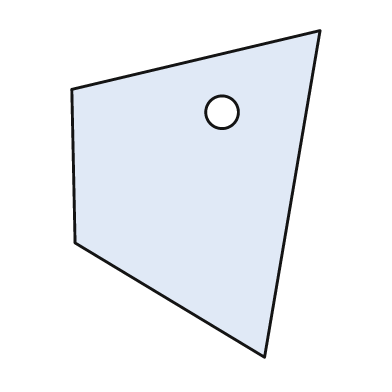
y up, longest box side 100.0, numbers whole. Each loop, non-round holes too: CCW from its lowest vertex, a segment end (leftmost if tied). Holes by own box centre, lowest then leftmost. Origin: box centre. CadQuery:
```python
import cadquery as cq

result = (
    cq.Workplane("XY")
    .moveTo(21.0, -50.0)
    .lineTo(38.0, 50.0)
    .lineTo(-38.0, 32.0)
    .lineTo(-37.0, -15.0)
    .close()
    .moveTo(8.0, 25.0)
    .circle(5.0)
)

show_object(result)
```